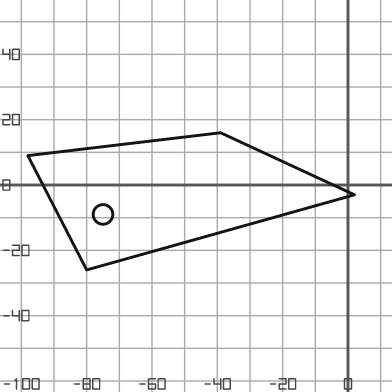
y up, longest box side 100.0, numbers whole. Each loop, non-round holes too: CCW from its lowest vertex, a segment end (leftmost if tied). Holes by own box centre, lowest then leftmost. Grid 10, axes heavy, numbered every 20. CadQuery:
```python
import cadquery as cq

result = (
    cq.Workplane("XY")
    .moveTo(-80.0, -26.0)
    .lineTo(2.0, -3.0)
    .lineTo(-39.0, 16.0)
    .lineTo(-98.0, 9.0)
    .close()
    .moveTo(-75.0, -9.0)
    .circle(3.0)
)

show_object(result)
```